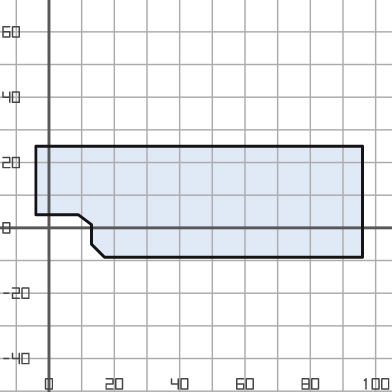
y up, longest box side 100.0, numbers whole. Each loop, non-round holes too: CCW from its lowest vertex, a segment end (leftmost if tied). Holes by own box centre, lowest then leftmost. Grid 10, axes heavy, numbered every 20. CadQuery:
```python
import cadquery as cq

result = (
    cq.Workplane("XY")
    .moveTo(17.0, -9.0)
    .lineTo(96.0, -9.0)
    .lineTo(96.0, 25.0)
    .lineTo(-4.0, 25.0)
    .lineTo(-4.0, 4.0)
    .lineTo(9.0, 4.0)
    .lineTo(13.0, 1.0)
    .lineTo(13.0, -5.0)
    .close()
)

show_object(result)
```